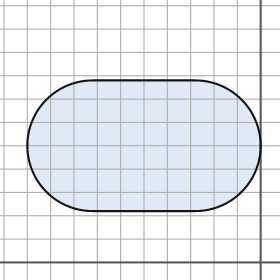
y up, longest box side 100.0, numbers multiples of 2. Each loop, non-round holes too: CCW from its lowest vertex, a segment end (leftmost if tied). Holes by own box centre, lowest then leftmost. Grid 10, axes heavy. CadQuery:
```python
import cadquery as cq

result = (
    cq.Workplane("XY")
    .moveTo(-72.0, 22.0)
    .lineTo(-28.0, 22.0)
    .threePointArc((0.0, 50.0), (-28.0, 78.0))
    .lineTo(-72.0, 78.0)
    .threePointArc((-100.0, 50.0), (-72.0, 22.0))
    .close()
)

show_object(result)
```